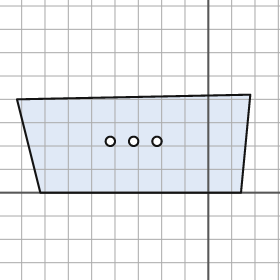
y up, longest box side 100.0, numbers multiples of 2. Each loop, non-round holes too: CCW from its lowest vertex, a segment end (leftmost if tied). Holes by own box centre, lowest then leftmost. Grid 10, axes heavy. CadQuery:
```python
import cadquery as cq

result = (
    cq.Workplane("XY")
    .moveTo(-72.0, 0.0)
    .lineTo(14.0, 0.0)
    .lineTo(18.0, 42.0)
    .lineTo(-82.0, 40.0)
    .close()
    .moveTo(-42.0, 22.0)
    .circle(2.0)
    .moveTo(-32.0, 22.0)
    .circle(2.0)
    .moveTo(-22.0, 22.0)
    .circle(2.0)
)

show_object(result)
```